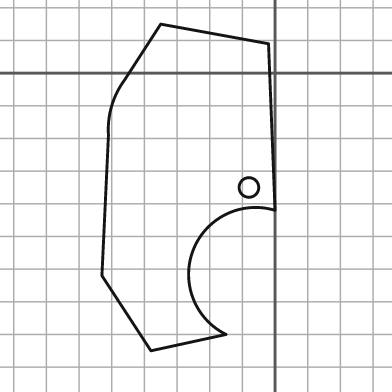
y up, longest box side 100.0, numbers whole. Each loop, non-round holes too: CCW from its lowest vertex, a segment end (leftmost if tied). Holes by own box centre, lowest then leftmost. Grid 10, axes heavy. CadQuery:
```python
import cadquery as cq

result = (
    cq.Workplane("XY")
    .moveTo(-38.0, -85.0)
    .lineTo(-15.0, -80.0)
    .threePointArc((-25.0, -54.0), (0.0, -42.0))
    .lineTo(-2.0, 9.0)
    .lineTo(-35.0, 15.0)
    .lineTo(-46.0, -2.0)
    .threePointArc((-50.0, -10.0), (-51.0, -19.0))
    .lineTo(-53.0, -62.0)
    .close()
    .moveTo(-8.0, -35.0)
    .circle(3.0)
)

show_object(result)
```